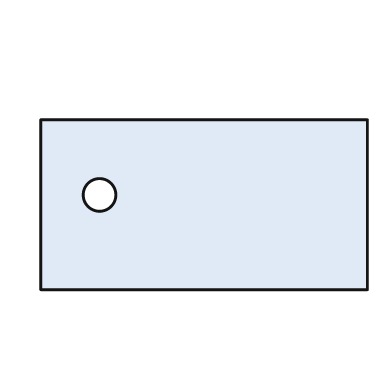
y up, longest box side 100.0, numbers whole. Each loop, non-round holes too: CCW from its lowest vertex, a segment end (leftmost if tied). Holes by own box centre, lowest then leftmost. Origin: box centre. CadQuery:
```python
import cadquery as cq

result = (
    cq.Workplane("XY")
    .moveTo(-50.0, -26.0)
    .lineTo(50.0, -26.0)
    .lineTo(50.0, 26.0)
    .lineTo(-50.0, 26.0)
    .close()
    .moveTo(-32.0, 3.0)
    .circle(5.0)
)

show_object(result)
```